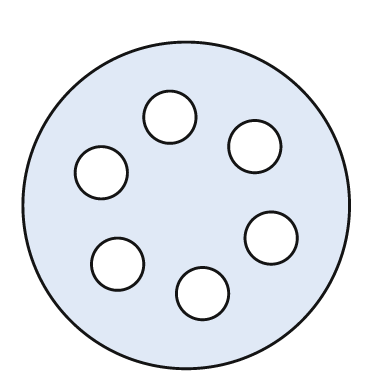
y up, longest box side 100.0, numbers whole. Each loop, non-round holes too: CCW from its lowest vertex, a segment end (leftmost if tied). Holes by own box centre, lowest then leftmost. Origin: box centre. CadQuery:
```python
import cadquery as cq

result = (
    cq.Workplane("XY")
    .moveTo(0.0, 0.0)
    .circle(50.0)
    .moveTo(5.0, -27.0)
    .circle(8.0)
    .moveTo(-21.0, -18.0)
    .circle(8.0)
    .moveTo(26.0, -10.0)
    .circle(8.0)
    .moveTo(-26.0, 10.0)
    .circle(8.0)
    .moveTo(21.0, 18.0)
    .circle(8.0)
    .moveTo(-5.0, 27.0)
    .circle(8.0)
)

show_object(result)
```